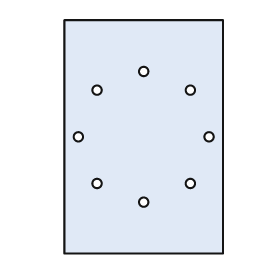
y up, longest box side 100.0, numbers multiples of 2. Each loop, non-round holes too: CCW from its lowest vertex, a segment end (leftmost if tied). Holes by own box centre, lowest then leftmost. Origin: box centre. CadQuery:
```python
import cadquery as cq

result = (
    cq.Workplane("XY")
    .moveTo(-34.0, -50.0)
    .lineTo(34.0, -50.0)
    .lineTo(34.0, 50.0)
    .lineTo(-34.0, 50.0)
    .close()
    .moveTo(0.0, -28.0)
    .circle(2.0)
    .moveTo(-20.0, -20.0)
    .circle(2.0)
    .moveTo(20.0, -20.0)
    .circle(2.0)
    .moveTo(-28.0, 0.0)
    .circle(2.0)
    .moveTo(28.0, 0.0)
    .circle(2.0)
    .moveTo(-20.0, 20.0)
    .circle(2.0)
    .moveTo(20.0, 20.0)
    .circle(2.0)
    .moveTo(0.0, 28.0)
    .circle(2.0)
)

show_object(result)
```